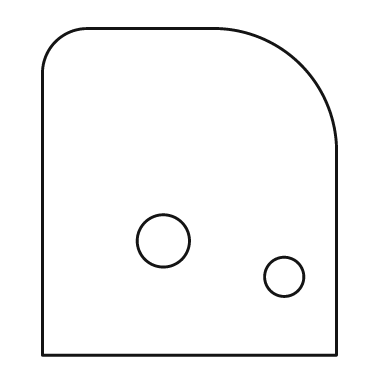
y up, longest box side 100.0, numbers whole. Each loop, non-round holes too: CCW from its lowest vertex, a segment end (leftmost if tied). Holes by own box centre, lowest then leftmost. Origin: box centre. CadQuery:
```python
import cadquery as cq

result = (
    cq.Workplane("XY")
    .moveTo(-45.0, -50.0)
    .lineTo(45.0, -50.0)
    .lineTo(45.0, 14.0)
    .threePointArc((34.0, 39.0), (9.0, 50.0))
    .lineTo(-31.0, 50.0)
    .threePointArc((-41.0, 46.0), (-45.0, 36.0))
    .close()
    .moveTo(29.0, -26.0)
    .circle(6.0)
    .moveTo(-8.0, -15.0)
    .circle(8.0)
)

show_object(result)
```